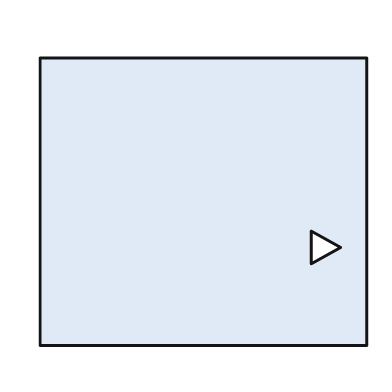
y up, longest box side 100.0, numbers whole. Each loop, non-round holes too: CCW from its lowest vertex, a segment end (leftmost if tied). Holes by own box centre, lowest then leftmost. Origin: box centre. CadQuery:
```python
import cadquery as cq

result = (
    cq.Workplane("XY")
    .moveTo(-50.0, -44.0)
    .lineTo(50.0, -44.0)
    .lineTo(50.0, 44.0)
    .lineTo(-50.0, 44.0)
    .close()
    .moveTo(33.0, -19.0)
    .lineTo(42.0, -14.0)
    .lineTo(33.0, -9.0)
    .close()
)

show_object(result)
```